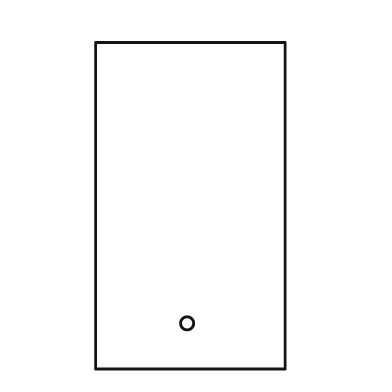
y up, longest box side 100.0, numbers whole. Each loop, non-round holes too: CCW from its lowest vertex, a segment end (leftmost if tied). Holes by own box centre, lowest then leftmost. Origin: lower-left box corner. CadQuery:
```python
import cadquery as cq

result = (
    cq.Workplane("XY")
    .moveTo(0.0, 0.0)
    .lineTo(58.0, 0.0)
    .lineTo(58.0, 100.0)
    .lineTo(0.0, 100.0)
    .close()
    .moveTo(28.0, 14.0)
    .circle(2.0)
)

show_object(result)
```